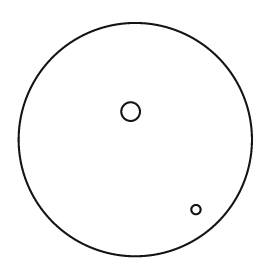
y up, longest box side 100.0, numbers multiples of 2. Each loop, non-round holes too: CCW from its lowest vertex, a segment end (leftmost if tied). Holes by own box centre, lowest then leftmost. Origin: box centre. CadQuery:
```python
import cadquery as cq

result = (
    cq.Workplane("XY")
    .moveTo(0.0, 0.0)
    .circle(50.0)
    .moveTo(26.0, -30.0)
    .circle(2.0)
    .moveTo(-2.0, 12.0)
    .circle(4.0)
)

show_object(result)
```